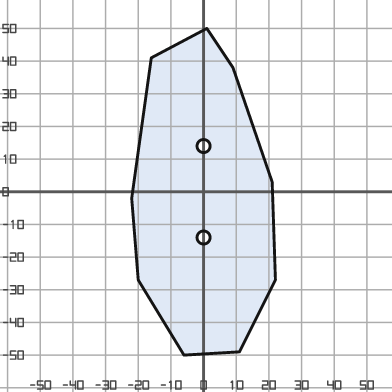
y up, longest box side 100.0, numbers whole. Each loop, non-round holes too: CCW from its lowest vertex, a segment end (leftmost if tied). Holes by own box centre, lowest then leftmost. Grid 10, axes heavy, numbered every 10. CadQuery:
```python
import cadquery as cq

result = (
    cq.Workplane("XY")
    .moveTo(-6.0, -50.0)
    .lineTo(11.0, -49.0)
    .lineTo(22.0, -27.0)
    .lineTo(21.0, 3.0)
    .lineTo(9.0, 38.0)
    .lineTo(1.0, 50.0)
    .lineTo(-16.0, 41.0)
    .lineTo(-22.0, -2.0)
    .lineTo(-20.0, -27.0)
    .close()
    .moveTo(0.0, -14.0)
    .circle(2.0)
    .moveTo(0.0, 14.0)
    .circle(2.0)
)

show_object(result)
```